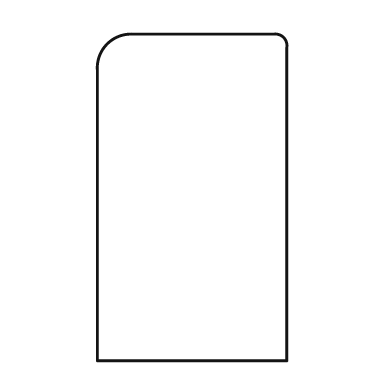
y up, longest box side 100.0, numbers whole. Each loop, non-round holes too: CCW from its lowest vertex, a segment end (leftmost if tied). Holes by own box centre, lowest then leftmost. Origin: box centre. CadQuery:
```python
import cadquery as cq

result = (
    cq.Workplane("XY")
    .moveTo(-29.0, -50.0)
    .lineTo(29.0, -50.0)
    .lineTo(29.0, 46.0)
    .threePointArc((28.0, 49.0), (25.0, 50.0))
    .lineTo(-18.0, 50.0)
    .threePointArc((-26.0, 47.0), (-29.0, 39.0))
    .close()
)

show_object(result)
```